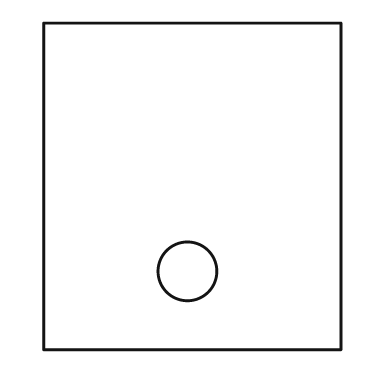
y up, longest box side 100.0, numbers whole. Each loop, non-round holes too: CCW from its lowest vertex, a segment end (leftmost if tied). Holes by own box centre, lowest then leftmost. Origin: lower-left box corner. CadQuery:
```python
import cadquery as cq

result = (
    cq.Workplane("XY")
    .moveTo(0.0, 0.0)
    .lineTo(91.0, 0.0)
    .lineTo(91.0, 100.0)
    .lineTo(0.0, 100.0)
    .close()
    .moveTo(44.0, 24.0)
    .circle(9.0)
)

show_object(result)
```